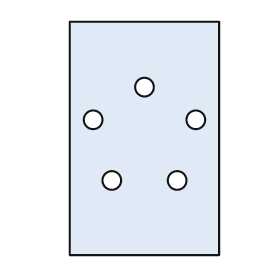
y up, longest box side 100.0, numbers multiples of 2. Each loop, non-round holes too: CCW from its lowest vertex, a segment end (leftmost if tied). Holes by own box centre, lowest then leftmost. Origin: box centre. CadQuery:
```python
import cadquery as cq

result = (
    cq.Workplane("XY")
    .moveTo(-32.0, -50.0)
    .lineTo(32.0, -50.0)
    .lineTo(32.0, 50.0)
    .lineTo(-32.0, 50.0)
    .close()
    .moveTo(-14.0, -18.0)
    .circle(4.0)
    .moveTo(14.0, -18.0)
    .circle(4.0)
    .moveTo(-22.0, 8.0)
    .circle(4.0)
    .moveTo(22.0, 8.0)
    .circle(4.0)
    .moveTo(0.0, 22.0)
    .circle(4.0)
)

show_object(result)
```